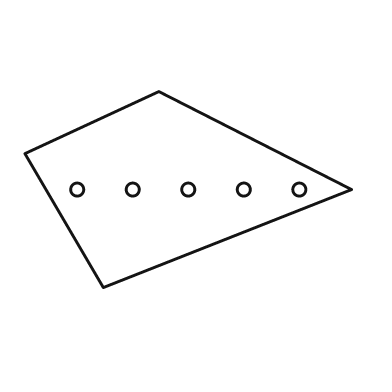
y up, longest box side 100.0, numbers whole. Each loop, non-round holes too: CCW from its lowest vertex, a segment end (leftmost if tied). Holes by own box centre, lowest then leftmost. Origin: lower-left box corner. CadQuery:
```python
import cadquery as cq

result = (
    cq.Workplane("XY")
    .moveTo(24.0, 0.0)
    .lineTo(100.0, 30.0)
    .lineTo(41.0, 60.0)
    .lineTo(0.0, 41.0)
    .close()
    .moveTo(16.0, 30.0)
    .circle(2.0)
    .moveTo(33.0, 30.0)
    .circle(2.0)
    .moveTo(50.0, 30.0)
    .circle(2.0)
    .moveTo(67.0, 30.0)
    .circle(2.0)
    .moveTo(84.0, 30.0)
    .circle(2.0)
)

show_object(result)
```